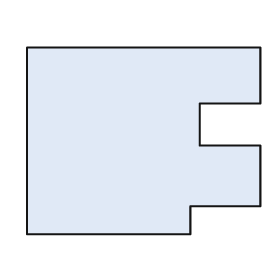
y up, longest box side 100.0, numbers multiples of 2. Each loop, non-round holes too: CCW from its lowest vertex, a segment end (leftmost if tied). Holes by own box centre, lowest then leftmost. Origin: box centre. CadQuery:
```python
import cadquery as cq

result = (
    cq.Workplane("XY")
    .moveTo(-50.0, -40.0)
    .lineTo(20.0, -40.0)
    .lineTo(20.0, -28.0)
    .lineTo(50.0, -28.0)
    .lineTo(50.0, -2.0)
    .lineTo(24.0, -2.0)
    .lineTo(24.0, 16.0)
    .lineTo(50.0, 16.0)
    .lineTo(50.0, 40.0)
    .lineTo(-50.0, 40.0)
    .close()
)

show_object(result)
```